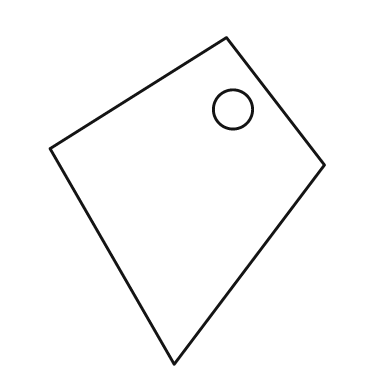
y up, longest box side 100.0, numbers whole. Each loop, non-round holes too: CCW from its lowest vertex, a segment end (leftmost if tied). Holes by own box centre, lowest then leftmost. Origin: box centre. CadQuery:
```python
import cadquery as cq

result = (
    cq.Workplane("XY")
    .moveTo(-4.0, -50.0)
    .lineTo(42.0, 11.0)
    .lineTo(12.0, 50.0)
    .lineTo(-42.0, 16.0)
    .close()
    .moveTo(14.0, 28.0)
    .circle(6.0)
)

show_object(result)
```